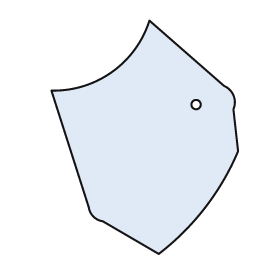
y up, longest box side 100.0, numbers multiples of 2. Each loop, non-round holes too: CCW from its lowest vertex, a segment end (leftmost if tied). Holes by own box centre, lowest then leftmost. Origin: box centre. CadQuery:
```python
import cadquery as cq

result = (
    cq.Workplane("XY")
    .moveTo(6.0, -50.0)
    .threePointArc((26.0, -30.0), (40.0, -6.0))
    .lineTo(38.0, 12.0)
    .threePointArc((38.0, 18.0), (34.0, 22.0))
    .lineTo(2.0, 50.0)
    .threePointArc((-14.0, 28.0), (-40.0, 20.0))
    .lineTo(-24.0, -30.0)
    .threePointArc((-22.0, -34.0), (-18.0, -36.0))
    .close()
    .moveTo(22.0, 14.0)
    .circle(2.0)
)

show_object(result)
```